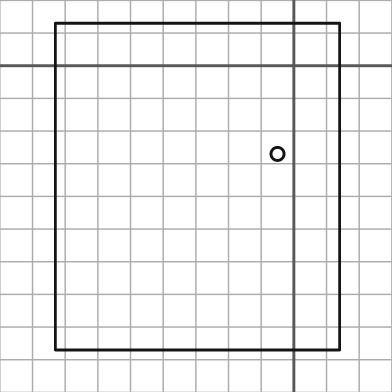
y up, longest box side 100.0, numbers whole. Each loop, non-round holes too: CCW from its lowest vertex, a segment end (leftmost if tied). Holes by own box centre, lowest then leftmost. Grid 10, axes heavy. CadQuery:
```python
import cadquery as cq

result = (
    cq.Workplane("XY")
    .moveTo(-73.0, -87.0)
    .lineTo(14.0, -87.0)
    .lineTo(14.0, 13.0)
    .lineTo(-73.0, 13.0)
    .close()
    .moveTo(-5.0, -27.0)
    .circle(2.0)
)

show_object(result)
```